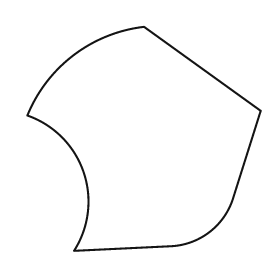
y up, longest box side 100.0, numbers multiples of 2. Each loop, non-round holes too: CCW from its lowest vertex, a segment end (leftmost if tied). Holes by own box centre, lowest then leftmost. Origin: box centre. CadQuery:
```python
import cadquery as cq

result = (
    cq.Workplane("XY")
    .moveTo(-30.0, -48.0)
    .lineTo(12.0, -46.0)
    .threePointArc((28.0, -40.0), (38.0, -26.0))
    .lineTo(50.0, 12.0)
    .lineTo(0.0, 48.0)
    .threePointArc((-30.0, 36.0), (-50.0, 10.0))
    .threePointArc((-26.0, -14.0), (-30.0, -48.0))
    .close()
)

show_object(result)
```